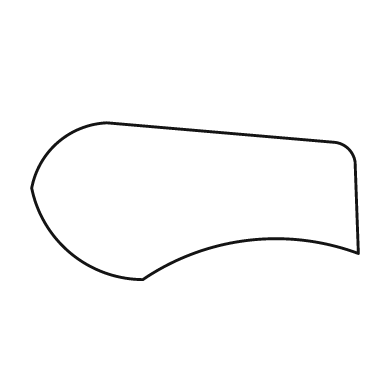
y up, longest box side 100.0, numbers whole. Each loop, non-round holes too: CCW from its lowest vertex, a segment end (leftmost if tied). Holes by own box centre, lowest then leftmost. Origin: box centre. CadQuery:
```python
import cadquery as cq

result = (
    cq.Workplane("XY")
    .moveTo(-16.0, -24.0)
    .threePointArc((16.0, -12.0), (50.0, -16.0))
    .lineTo(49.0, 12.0)
    .threePointArc((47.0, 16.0), (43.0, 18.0))
    .lineTo(-27.0, 24.0)
    .threePointArc((-42.0, 18.0), (-50.0, 4.0))
    .threePointArc((-38.0, -16.0), (-16.0, -24.0))
    .close()
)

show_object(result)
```